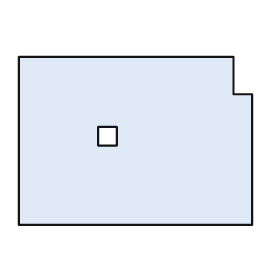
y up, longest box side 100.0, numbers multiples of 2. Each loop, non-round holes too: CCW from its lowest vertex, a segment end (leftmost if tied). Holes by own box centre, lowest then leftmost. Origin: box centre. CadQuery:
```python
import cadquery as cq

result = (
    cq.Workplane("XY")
    .moveTo(-50.0, -36.0)
    .lineTo(50.0, -36.0)
    .lineTo(50.0, 20.0)
    .lineTo(42.0, 20.0)
    .lineTo(42.0, 36.0)
    .lineTo(-50.0, 36.0)
    .close()
    .moveTo(-16.0, -2.0)
    .lineTo(-8.0, -2.0)
    .lineTo(-8.0, 6.0)
    .lineTo(-16.0, 6.0)
    .close()
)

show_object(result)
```